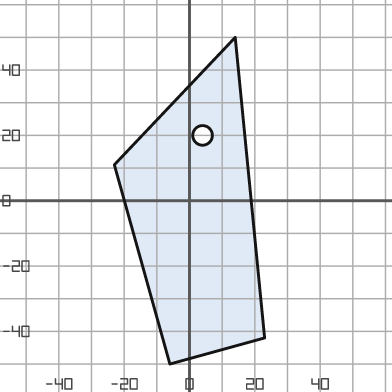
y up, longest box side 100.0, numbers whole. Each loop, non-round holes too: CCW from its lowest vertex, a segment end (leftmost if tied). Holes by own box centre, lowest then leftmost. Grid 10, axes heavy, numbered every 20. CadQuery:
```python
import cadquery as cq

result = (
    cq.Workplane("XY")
    .moveTo(-6.0, -50.0)
    .lineTo(23.0, -42.0)
    .lineTo(14.0, 50.0)
    .lineTo(-23.0, 11.0)
    .close()
    .moveTo(4.0, 20.0)
    .circle(3.0)
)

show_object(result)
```